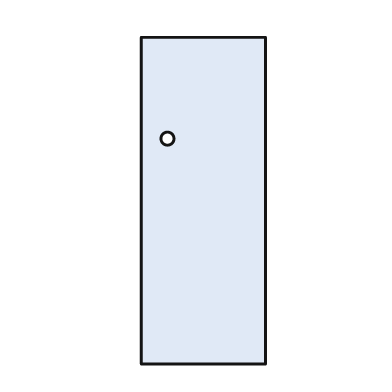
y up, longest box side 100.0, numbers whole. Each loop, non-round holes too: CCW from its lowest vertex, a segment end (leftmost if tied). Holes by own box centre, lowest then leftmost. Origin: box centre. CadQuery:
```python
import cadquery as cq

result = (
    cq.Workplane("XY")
    .moveTo(-19.0, -50.0)
    .lineTo(19.0, -50.0)
    .lineTo(19.0, 50.0)
    .lineTo(-19.0, 50.0)
    .close()
    .moveTo(-11.0, 19.0)
    .circle(2.0)
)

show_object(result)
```